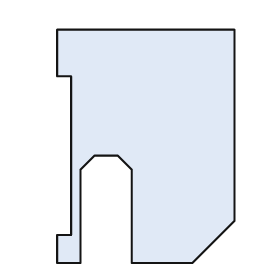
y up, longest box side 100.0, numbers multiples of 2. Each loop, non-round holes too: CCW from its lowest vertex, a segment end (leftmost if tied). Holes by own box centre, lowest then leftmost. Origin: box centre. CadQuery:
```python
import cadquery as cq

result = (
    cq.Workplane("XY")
    .moveTo(-38.0, -50.0)
    .lineTo(-28.0, -50.0)
    .lineTo(-28.0, -10.0)
    .lineTo(-22.0, -4.0)
    .lineTo(-12.0, -4.0)
    .lineTo(-6.0, -10.0)
    .lineTo(-6.0, -50.0)
    .lineTo(20.0, -50.0)
    .lineTo(38.0, -32.0)
    .lineTo(38.0, 50.0)
    .lineTo(-38.0, 50.0)
    .lineTo(-38.0, 30.0)
    .lineTo(-32.0, 30.0)
    .lineTo(-32.0, -38.0)
    .lineTo(-38.0, -38.0)
    .close()
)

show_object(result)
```